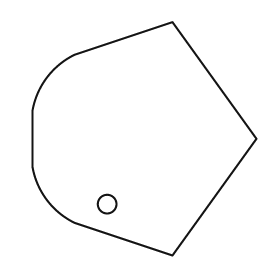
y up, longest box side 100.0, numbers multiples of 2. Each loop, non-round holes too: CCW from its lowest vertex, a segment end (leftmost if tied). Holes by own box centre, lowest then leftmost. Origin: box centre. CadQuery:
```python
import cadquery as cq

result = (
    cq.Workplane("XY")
    .moveTo(12.0, -50.0)
    .lineTo(48.0, 0.0)
    .lineTo(12.0, 50.0)
    .lineTo(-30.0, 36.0)
    .threePointArc((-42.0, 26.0), (-48.0, 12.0))
    .lineTo(-48.0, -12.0)
    .threePointArc((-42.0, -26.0), (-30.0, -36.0))
    .close()
    .moveTo(-16.0, -28.0)
    .circle(4.0)
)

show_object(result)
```